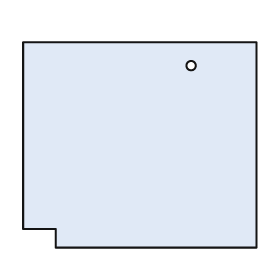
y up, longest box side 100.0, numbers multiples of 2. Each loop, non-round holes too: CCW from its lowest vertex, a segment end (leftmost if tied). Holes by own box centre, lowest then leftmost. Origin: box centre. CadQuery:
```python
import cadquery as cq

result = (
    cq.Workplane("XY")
    .moveTo(-36.0, -44.0)
    .lineTo(50.0, -44.0)
    .lineTo(50.0, 44.0)
    .lineTo(-50.0, 44.0)
    .lineTo(-50.0, -36.0)
    .lineTo(-36.0, -36.0)
    .close()
    .moveTo(22.0, 34.0)
    .circle(2.0)
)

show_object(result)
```